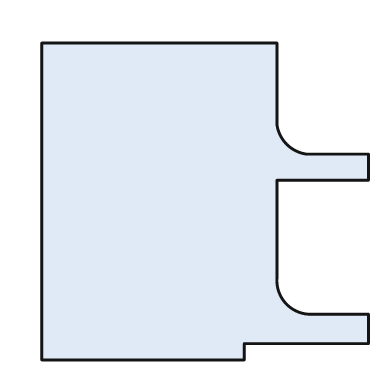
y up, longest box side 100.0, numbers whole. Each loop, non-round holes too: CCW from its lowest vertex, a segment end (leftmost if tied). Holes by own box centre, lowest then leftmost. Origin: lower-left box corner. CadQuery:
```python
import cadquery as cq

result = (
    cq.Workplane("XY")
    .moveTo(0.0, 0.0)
    .lineTo(62.0, 0.0)
    .lineTo(62.0, 5.0)
    .lineTo(100.0, 5.0)
    .lineTo(100.0, 14.0)
    .lineTo(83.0, 14.0)
    .threePointArc((75.0, 17.0), (72.0, 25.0))
    .lineTo(72.0, 55.0)
    .lineTo(100.0, 55.0)
    .lineTo(100.0, 63.0)
    .lineTo(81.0, 63.0)
    .threePointArc((75.0, 66.0), (72.0, 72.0))
    .lineTo(72.0, 97.0)
    .lineTo(0.0, 97.0)
    .close()
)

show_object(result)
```